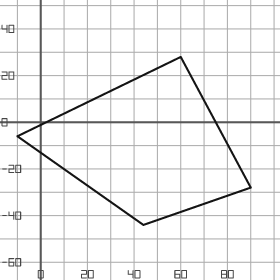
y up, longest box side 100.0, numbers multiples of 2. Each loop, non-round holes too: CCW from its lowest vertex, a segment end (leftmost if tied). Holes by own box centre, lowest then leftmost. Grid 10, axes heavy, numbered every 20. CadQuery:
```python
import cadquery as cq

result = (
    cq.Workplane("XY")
    .moveTo(44.0, -44.0)
    .lineTo(90.0, -28.0)
    .lineTo(60.0, 28.0)
    .lineTo(-10.0, -6.0)
    .close()
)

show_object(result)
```